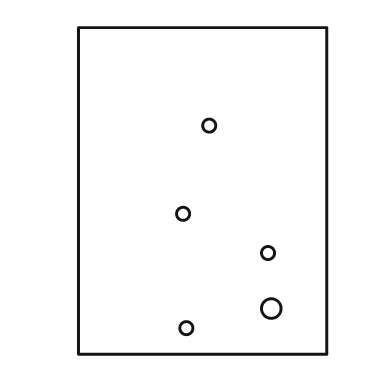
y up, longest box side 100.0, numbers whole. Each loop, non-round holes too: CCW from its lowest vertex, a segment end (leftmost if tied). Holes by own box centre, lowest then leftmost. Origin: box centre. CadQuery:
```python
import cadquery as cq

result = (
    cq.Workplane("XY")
    .moveTo(-38.0, -50.0)
    .lineTo(38.0, -50.0)
    .lineTo(38.0, 50.0)
    .lineTo(-38.0, 50.0)
    .close()
    .moveTo(-5.0, -42.0)
    .circle(2.0)
    .moveTo(21.0, -36.0)
    .circle(3.0)
    .moveTo(20.0, -19.0)
    .circle(2.0)
    .moveTo(-6.0, -7.0)
    .circle(2.0)
    .moveTo(2.0, 20.0)
    .circle(2.0)
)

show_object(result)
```